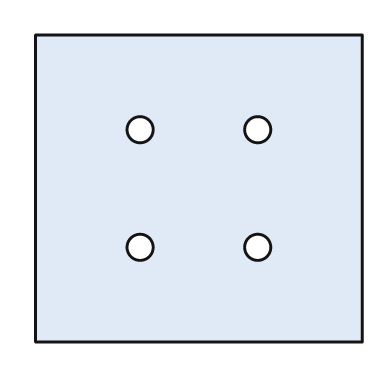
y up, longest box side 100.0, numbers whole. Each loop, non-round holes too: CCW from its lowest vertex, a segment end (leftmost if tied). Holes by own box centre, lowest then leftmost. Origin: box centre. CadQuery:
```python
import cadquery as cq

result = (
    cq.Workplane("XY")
    .moveTo(-50.0, -47.0)
    .lineTo(50.0, -47.0)
    .lineTo(50.0, 47.0)
    .lineTo(-50.0, 47.0)
    .close()
    .moveTo(-18.0, -18.0)
    .circle(4.0)
    .moveTo(18.0, -18.0)
    .circle(4.0)
    .moveTo(-18.0, 18.0)
    .circle(4.0)
    .moveTo(18.0, 18.0)
    .circle(4.0)
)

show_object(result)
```